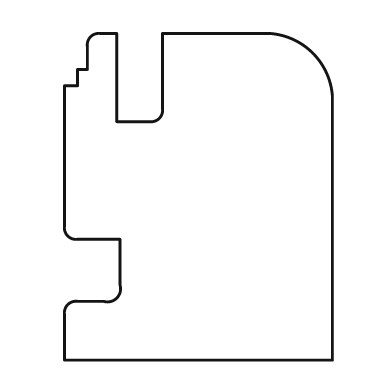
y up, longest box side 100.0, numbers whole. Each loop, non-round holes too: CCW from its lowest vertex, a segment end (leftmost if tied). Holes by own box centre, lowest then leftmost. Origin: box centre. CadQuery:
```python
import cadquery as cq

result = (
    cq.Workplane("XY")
    .moveTo(-41.0, -50.0)
    .lineTo(41.0, -50.0)
    .lineTo(41.0, 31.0)
    .threePointArc((35.0, 44.0), (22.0, 50.0))
    .lineTo(-11.0, 50.0)
    .lineTo(-11.0, 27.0)
    .threePointArc((-12.0, 24.0), (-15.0, 23.0))
    .lineTo(-25.0, 23.0)
    .lineTo(-25.0, 50.0)
    .lineTo(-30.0, 50.0)
    .threePointArc((-33.0, 49.0), (-34.0, 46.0))
    .lineTo(-34.0, 39.0)
    .lineTo(-37.0, 39.0)
    .lineTo(-37.0, 34.0)
    .lineTo(-41.0, 34.0)
    .lineTo(-41.0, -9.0)
    .threePointArc((-40.0, -12.0), (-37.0, -13.0))
    .lineTo(-24.0, -13.0)
    .lineTo(-24.0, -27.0)
    .threePointArc((-25.0, -31.0), (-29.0, -32.0))
    .lineTo(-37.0, -32.0)
    .threePointArc((-40.0, -33.0), (-41.0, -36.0))
    .close()
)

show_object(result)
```